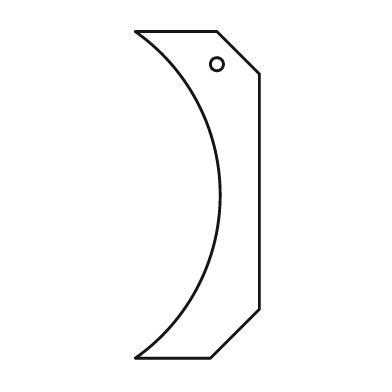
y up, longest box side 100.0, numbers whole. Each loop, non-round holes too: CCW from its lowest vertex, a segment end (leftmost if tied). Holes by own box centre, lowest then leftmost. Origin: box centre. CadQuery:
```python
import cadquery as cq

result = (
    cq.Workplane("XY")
    .moveTo(-19.0, -50.0)
    .lineTo(4.0, -50.0)
    .lineTo(19.0, -35.0)
    .lineTo(19.0, 37.0)
    .lineTo(6.0, 50.0)
    .lineTo(-19.0, 50.0)
    .threePointArc((7.0, 0.0), (-19.0, -50.0))
    .close()
    .moveTo(6.0, 40.0)
    .circle(2.0)
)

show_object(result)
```